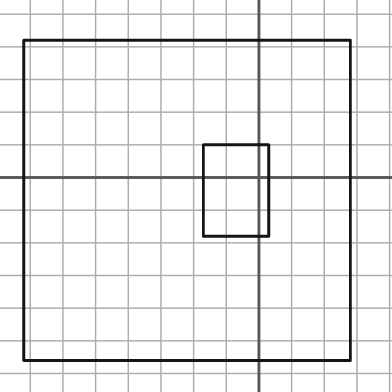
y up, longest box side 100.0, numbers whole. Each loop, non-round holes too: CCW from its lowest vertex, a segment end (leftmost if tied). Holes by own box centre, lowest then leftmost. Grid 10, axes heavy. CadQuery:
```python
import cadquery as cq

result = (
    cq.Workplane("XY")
    .moveTo(-72.0, -56.0)
    .lineTo(28.0, -56.0)
    .lineTo(28.0, 42.0)
    .lineTo(-72.0, 42.0)
    .close()
    .moveTo(-17.0, -18.0)
    .lineTo(3.0, -18.0)
    .lineTo(3.0, 10.0)
    .lineTo(-17.0, 10.0)
    .close()
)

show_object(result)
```